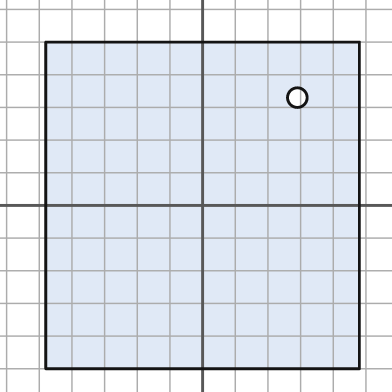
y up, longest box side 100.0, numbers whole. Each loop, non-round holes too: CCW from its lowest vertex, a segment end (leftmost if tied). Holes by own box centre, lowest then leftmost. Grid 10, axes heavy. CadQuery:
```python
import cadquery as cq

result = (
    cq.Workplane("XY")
    .moveTo(-48.0, -50.0)
    .lineTo(48.0, -50.0)
    .lineTo(48.0, 50.0)
    .lineTo(-48.0, 50.0)
    .close()
    .moveTo(29.0, 33.0)
    .circle(3.0)
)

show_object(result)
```